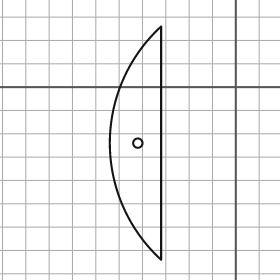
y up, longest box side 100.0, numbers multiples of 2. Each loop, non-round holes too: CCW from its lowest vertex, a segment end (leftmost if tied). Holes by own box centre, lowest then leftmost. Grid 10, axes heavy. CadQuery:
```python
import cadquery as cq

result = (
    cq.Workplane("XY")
    .moveTo(-32.0, -74.0)
    .lineTo(-32.0, 26.0)
    .threePointArc((-54.0, -24.0), (-32.0, -74.0))
    .close()
    .moveTo(-42.0, -24.0)
    .circle(2.0)
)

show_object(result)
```